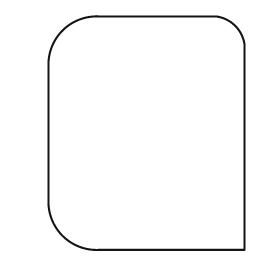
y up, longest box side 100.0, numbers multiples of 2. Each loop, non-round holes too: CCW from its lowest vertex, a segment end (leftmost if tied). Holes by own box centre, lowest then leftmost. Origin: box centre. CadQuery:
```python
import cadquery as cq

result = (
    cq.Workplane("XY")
    .moveTo(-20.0, -50.0)
    .lineTo(42.0, -50.0)
    .lineTo(42.0, 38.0)
    .threePointArc((38.0, 46.0), (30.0, 50.0))
    .lineTo(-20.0, 50.0)
    .threePointArc((-36.0, 44.0), (-42.0, 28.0))
    .lineTo(-42.0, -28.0)
    .threePointArc((-36.0, -44.0), (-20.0, -50.0))
    .close()
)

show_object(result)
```